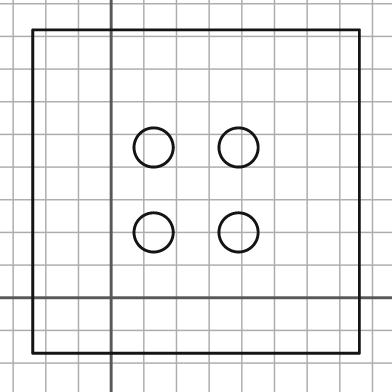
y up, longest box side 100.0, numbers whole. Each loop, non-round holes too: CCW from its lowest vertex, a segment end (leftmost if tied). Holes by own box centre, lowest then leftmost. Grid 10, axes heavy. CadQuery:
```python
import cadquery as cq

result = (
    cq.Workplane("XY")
    .moveTo(-24.0, -17.0)
    .lineTo(76.0, -17.0)
    .lineTo(76.0, 82.0)
    .lineTo(-24.0, 82.0)
    .close()
    .moveTo(13.0, 20.0)
    .circle(6.0)
    .moveTo(39.0, 20.0)
    .circle(6.0)
    .moveTo(13.0, 46.0)
    .circle(6.0)
    .moveTo(39.0, 46.0)
    .circle(6.0)
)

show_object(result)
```